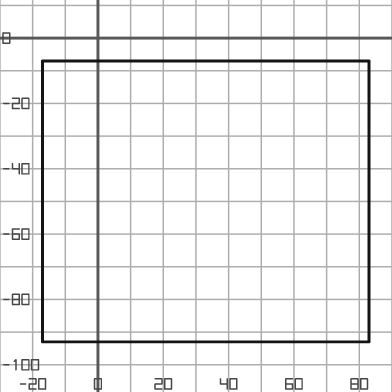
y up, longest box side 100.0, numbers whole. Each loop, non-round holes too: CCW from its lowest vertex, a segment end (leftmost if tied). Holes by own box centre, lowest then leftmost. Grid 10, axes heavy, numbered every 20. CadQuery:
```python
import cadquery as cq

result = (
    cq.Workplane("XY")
    .moveTo(-17.0, -93.0)
    .lineTo(83.0, -93.0)
    .lineTo(83.0, -7.0)
    .lineTo(-17.0, -7.0)
    .close()
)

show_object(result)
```